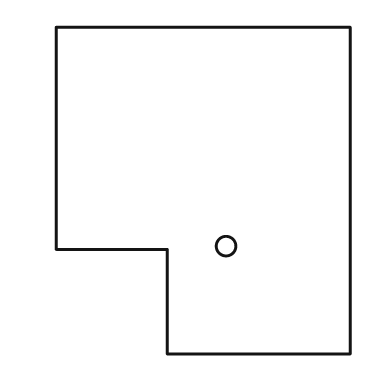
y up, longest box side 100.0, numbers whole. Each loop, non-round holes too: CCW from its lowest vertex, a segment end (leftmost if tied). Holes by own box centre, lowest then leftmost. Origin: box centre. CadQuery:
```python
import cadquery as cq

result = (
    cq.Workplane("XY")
    .moveTo(-11.0, -50.0)
    .lineTo(45.0, -50.0)
    .lineTo(45.0, 50.0)
    .lineTo(-45.0, 50.0)
    .lineTo(-45.0, -18.0)
    .lineTo(-11.0, -18.0)
    .close()
    .moveTo(7.0, -17.0)
    .circle(3.0)
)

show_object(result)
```